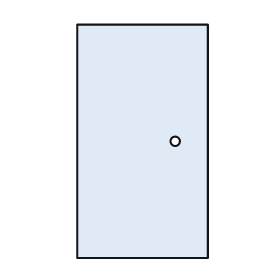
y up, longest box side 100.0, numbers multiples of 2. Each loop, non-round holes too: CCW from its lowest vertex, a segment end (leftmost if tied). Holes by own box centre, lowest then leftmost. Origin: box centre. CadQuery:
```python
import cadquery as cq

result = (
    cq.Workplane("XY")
    .moveTo(-28.0, -50.0)
    .lineTo(28.0, -50.0)
    .lineTo(28.0, 50.0)
    .lineTo(-28.0, 50.0)
    .close()
    .moveTo(14.0, 0.0)
    .circle(2.0)
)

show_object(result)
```